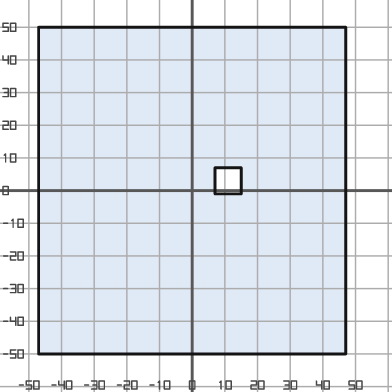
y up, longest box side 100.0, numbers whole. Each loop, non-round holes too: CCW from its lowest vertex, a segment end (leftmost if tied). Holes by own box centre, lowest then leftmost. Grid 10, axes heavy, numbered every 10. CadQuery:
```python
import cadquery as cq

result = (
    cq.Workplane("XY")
    .moveTo(-47.0, -50.0)
    .lineTo(47.0, -50.0)
    .lineTo(47.0, 50.0)
    .lineTo(-47.0, 50.0)
    .close()
    .moveTo(7.0, -1.0)
    .lineTo(15.0, -1.0)
    .lineTo(15.0, 7.0)
    .lineTo(7.0, 7.0)
    .close()
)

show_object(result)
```